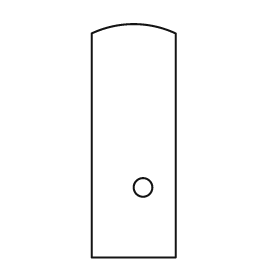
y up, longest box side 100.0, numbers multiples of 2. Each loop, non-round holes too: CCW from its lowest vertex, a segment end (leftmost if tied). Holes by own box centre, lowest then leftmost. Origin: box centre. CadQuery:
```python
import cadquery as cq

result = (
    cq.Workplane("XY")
    .moveTo(-18.0, -50.0)
    .lineTo(18.0, -50.0)
    .lineTo(18.0, 46.0)
    .threePointArc((0.0, 50.0), (-18.0, 46.0))
    .close()
    .moveTo(4.0, -20.0)
    .circle(4.0)
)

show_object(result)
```